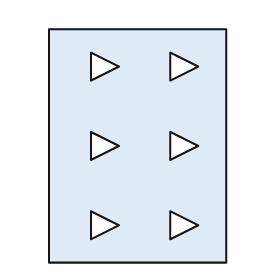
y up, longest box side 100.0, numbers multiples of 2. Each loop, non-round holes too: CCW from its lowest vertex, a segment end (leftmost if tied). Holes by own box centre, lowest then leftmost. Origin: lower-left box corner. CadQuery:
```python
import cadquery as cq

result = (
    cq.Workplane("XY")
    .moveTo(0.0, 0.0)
    .lineTo(76.0, 0.0)
    .lineTo(76.0, 100.0)
    .lineTo(0.0, 100.0)
    .close()
    .moveTo(18.0, 10.0)
    .lineTo(30.0, 16.0)
    .lineTo(18.0, 22.0)
    .close()
    .moveTo(52.0, 10.0)
    .lineTo(64.0, 16.0)
    .lineTo(52.0, 22.0)
    .close()
    .moveTo(18.0, 44.0)
    .lineTo(30.0, 50.0)
    .lineTo(18.0, 56.0)
    .close()
    .moveTo(52.0, 44.0)
    .lineTo(64.0, 50.0)
    .lineTo(52.0, 56.0)
    .close()
    .moveTo(18.0, 78.0)
    .lineTo(30.0, 84.0)
    .lineTo(18.0, 90.0)
    .close()
    .moveTo(52.0, 78.0)
    .lineTo(64.0, 84.0)
    .lineTo(52.0, 90.0)
    .close()
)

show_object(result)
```